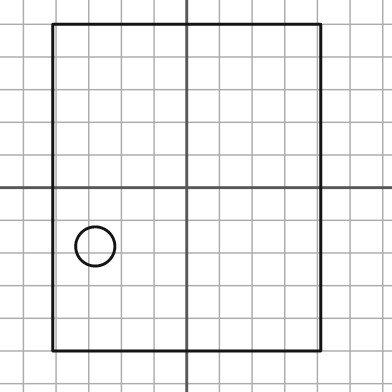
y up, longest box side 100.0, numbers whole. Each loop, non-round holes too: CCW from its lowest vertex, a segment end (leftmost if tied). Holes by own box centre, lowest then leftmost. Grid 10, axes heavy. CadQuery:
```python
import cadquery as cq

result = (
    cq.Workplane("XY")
    .moveTo(-41.0, -50.0)
    .lineTo(41.0, -50.0)
    .lineTo(41.0, 50.0)
    .lineTo(-41.0, 50.0)
    .close()
    .moveTo(-28.0, -18.0)
    .circle(6.0)
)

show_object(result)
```